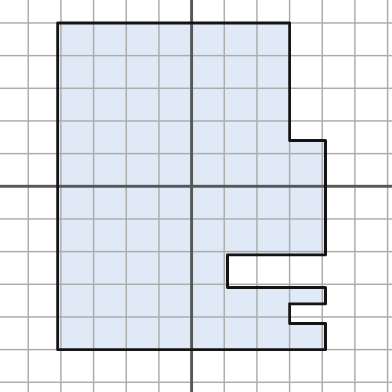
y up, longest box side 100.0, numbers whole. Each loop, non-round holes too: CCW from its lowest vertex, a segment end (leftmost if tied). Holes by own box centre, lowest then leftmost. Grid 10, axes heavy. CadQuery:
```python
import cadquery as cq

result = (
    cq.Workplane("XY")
    .moveTo(-41.0, -50.0)
    .lineTo(41.0, -50.0)
    .lineTo(41.0, -42.0)
    .lineTo(30.0, -42.0)
    .lineTo(30.0, -36.0)
    .lineTo(41.0, -36.0)
    .lineTo(41.0, -31.0)
    .lineTo(11.0, -31.0)
    .lineTo(11.0, -21.0)
    .lineTo(41.0, -21.0)
    .lineTo(41.0, 14.0)
    .lineTo(30.0, 14.0)
    .lineTo(30.0, 50.0)
    .lineTo(-41.0, 50.0)
    .close()
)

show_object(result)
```